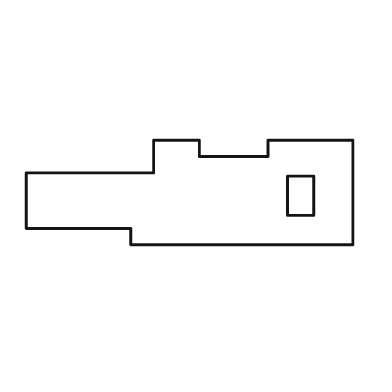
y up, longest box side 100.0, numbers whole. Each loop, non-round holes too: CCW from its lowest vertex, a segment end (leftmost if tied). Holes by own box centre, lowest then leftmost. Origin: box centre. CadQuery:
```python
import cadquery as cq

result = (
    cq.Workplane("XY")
    .moveTo(-18.0, -16.0)
    .lineTo(50.0, -16.0)
    .lineTo(50.0, 16.0)
    .lineTo(24.0, 16.0)
    .lineTo(24.0, 11.0)
    .lineTo(3.0, 11.0)
    .lineTo(3.0, 16.0)
    .lineTo(-11.0, 16.0)
    .lineTo(-11.0, 6.0)
    .lineTo(-50.0, 6.0)
    .lineTo(-50.0, -11.0)
    .lineTo(-18.0, -11.0)
    .close()
    .moveTo(30.0, -7.0)
    .lineTo(38.0, -7.0)
    .lineTo(38.0, 5.0)
    .lineTo(30.0, 5.0)
    .close()
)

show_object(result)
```